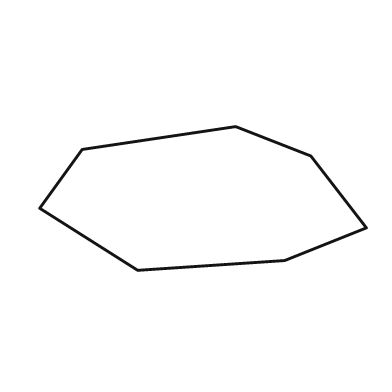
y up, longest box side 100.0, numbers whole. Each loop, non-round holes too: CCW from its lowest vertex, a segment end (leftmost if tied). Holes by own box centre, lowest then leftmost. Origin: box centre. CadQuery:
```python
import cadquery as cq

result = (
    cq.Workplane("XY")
    .moveTo(-20.0, -22.0)
    .lineTo(25.0, -19.0)
    .lineTo(50.0, -9.0)
    .lineTo(33.0, 13.0)
    .lineTo(10.0, 22.0)
    .lineTo(-37.0, 15.0)
    .lineTo(-50.0, -3.0)
    .close()
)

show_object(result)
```